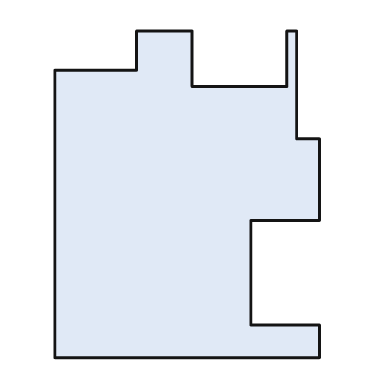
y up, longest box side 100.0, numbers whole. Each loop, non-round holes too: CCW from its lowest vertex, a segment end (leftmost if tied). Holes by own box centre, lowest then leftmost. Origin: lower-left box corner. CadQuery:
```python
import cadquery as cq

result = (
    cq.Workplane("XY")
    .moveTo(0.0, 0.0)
    .lineTo(81.0, 0.0)
    .lineTo(81.0, 10.0)
    .lineTo(60.0, 10.0)
    .lineTo(60.0, 42.0)
    .lineTo(81.0, 42.0)
    .lineTo(81.0, 67.0)
    .lineTo(74.0, 67.0)
    .lineTo(74.0, 100.0)
    .lineTo(71.0, 100.0)
    .lineTo(71.0, 83.0)
    .lineTo(42.0, 83.0)
    .lineTo(42.0, 100.0)
    .lineTo(25.0, 100.0)
    .lineTo(25.0, 88.0)
    .lineTo(0.0, 88.0)
    .close()
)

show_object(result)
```